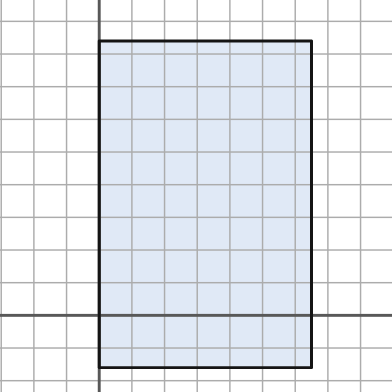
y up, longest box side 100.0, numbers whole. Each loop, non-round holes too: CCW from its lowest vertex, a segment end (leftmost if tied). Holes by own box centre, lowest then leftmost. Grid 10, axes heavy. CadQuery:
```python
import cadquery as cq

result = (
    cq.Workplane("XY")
    .moveTo(0.0, -16.0)
    .lineTo(65.0, -16.0)
    .lineTo(65.0, 84.0)
    .lineTo(0.0, 84.0)
    .close()
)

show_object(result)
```